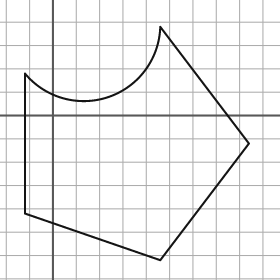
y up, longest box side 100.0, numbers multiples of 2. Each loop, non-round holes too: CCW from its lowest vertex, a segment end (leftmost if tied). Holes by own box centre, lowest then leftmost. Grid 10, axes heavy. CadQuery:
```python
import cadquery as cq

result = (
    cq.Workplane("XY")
    .moveTo(46.0, -62.0)
    .lineTo(84.0, -12.0)
    .lineTo(46.0, 38.0)
    .threePointArc((24.0, 8.0), (-12.0, 18.0))
    .lineTo(-12.0, -42.0)
    .close()
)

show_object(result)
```